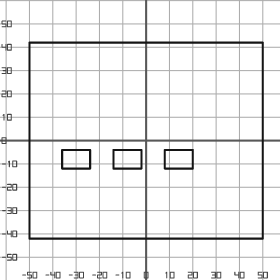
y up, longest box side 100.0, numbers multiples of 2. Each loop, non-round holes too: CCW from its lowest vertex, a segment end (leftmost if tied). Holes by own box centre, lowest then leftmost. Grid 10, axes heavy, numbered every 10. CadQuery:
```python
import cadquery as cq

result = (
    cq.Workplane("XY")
    .moveTo(-50.0, -42.0)
    .lineTo(50.0, -42.0)
    .lineTo(50.0, 42.0)
    .lineTo(-50.0, 42.0)
    .close()
    .moveTo(-36.0, -12.0)
    .lineTo(-24.0, -12.0)
    .lineTo(-24.0, -4.0)
    .lineTo(-36.0, -4.0)
    .close()
    .moveTo(-14.0, -12.0)
    .lineTo(-2.0, -12.0)
    .lineTo(-2.0, -4.0)
    .lineTo(-14.0, -4.0)
    .close()
    .moveTo(8.0, -12.0)
    .lineTo(20.0, -12.0)
    .lineTo(20.0, -4.0)
    .lineTo(8.0, -4.0)
    .close()
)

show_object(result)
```